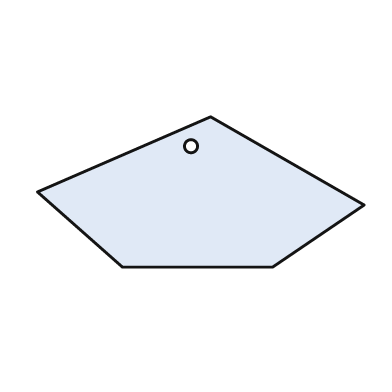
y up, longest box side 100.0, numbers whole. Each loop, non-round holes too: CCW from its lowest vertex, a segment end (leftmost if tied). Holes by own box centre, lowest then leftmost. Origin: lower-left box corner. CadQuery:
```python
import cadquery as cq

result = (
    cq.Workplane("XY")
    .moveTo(26.0, 0.0)
    .lineTo(72.0, 0.0)
    .lineTo(100.0, 19.0)
    .lineTo(53.0, 46.0)
    .lineTo(0.0, 23.0)
    .close()
    .moveTo(47.0, 37.0)
    .circle(2.0)
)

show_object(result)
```